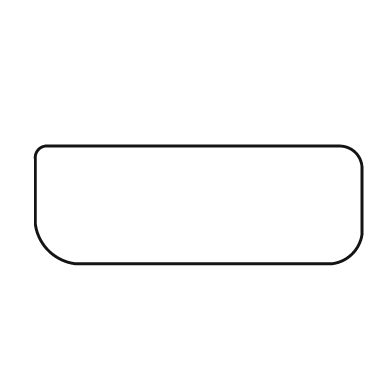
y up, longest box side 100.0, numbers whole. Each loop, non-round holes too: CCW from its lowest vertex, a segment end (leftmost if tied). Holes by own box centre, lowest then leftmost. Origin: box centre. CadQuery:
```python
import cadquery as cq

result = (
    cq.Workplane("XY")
    .moveTo(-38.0, -18.0)
    .lineTo(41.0, -18.0)
    .threePointArc((47.0, -15.0), (50.0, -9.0))
    .lineTo(50.0, 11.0)
    .threePointArc((48.0, 16.0), (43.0, 18.0))
    .lineTo(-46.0, 18.0)
    .threePointArc((-49.0, 17.0), (-50.0, 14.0))
    .lineTo(-50.0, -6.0)
    .threePointArc((-46.0, -14.0), (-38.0, -18.0))
    .close()
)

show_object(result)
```